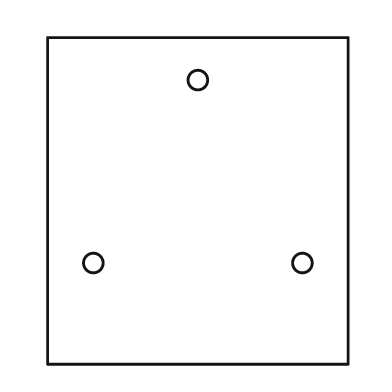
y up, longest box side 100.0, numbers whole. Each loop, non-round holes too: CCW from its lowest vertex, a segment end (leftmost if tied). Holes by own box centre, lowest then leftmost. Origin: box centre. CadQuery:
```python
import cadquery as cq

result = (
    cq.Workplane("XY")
    .moveTo(-46.0, -50.0)
    .lineTo(46.0, -50.0)
    .lineTo(46.0, 50.0)
    .lineTo(-46.0, 50.0)
    .close()
    .moveTo(-32.0, -19.0)
    .circle(3.0)
    .moveTo(32.0, -19.0)
    .circle(3.0)
    .moveTo(0.0, 37.0)
    .circle(3.0)
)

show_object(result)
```